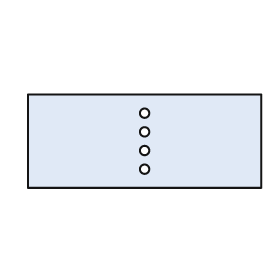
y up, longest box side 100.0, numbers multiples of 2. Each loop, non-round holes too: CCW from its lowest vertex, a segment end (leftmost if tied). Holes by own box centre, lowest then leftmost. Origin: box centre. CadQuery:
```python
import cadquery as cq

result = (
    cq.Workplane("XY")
    .moveTo(-50.0, -20.0)
    .lineTo(50.0, -20.0)
    .lineTo(50.0, 20.0)
    .lineTo(-50.0, 20.0)
    .close()
    .moveTo(0.0, -12.0)
    .circle(2.0)
    .moveTo(0.0, -4.0)
    .circle(2.0)
    .moveTo(0.0, 4.0)
    .circle(2.0)
    .moveTo(0.0, 12.0)
    .circle(2.0)
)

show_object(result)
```